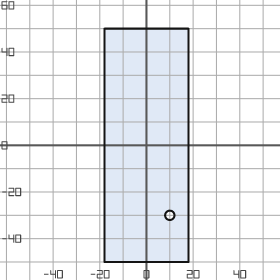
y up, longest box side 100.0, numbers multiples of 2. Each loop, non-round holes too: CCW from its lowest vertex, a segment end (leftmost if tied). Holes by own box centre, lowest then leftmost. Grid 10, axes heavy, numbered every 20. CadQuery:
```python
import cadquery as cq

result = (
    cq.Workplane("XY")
    .moveTo(-18.0, -50.0)
    .lineTo(18.0, -50.0)
    .lineTo(18.0, 50.0)
    .lineTo(-18.0, 50.0)
    .close()
    .moveTo(10.0, -30.0)
    .circle(2.0)
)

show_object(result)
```